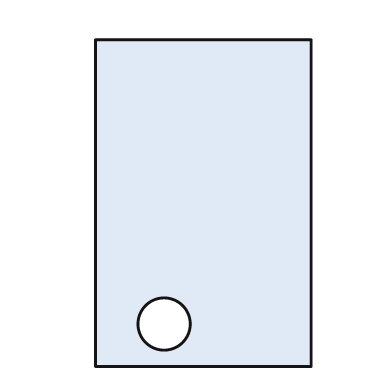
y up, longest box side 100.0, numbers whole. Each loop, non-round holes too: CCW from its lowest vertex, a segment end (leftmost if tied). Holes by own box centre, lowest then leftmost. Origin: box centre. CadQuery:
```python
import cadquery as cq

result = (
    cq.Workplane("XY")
    .moveTo(-33.0, -50.0)
    .lineTo(33.0, -50.0)
    .lineTo(33.0, 50.0)
    .lineTo(-33.0, 50.0)
    .close()
    .moveTo(-12.0, -37.0)
    .circle(8.0)
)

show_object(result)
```